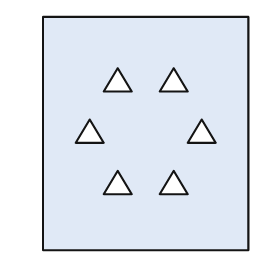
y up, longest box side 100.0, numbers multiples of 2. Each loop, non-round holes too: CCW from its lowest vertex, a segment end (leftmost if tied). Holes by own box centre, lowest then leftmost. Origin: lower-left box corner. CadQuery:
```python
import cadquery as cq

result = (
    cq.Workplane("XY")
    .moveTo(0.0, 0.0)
    .lineTo(88.0, 0.0)
    .lineTo(88.0, 100.0)
    .lineTo(0.0, 100.0)
    .close()
    .moveTo(26.0, 24.0)
    .lineTo(38.0, 24.0)
    .lineTo(32.0, 34.0)
    .close()
    .moveTo(50.0, 24.0)
    .lineTo(62.0, 24.0)
    .lineTo(56.0, 34.0)
    .close()
    .moveTo(14.0, 46.0)
    .lineTo(26.0, 46.0)
    .lineTo(20.0, 56.0)
    .close()
    .moveTo(62.0, 46.0)
    .lineTo(74.0, 46.0)
    .lineTo(68.0, 56.0)
    .close()
    .moveTo(26.0, 68.0)
    .lineTo(38.0, 68.0)
    .lineTo(32.0, 78.0)
    .close()
    .moveTo(50.0, 68.0)
    .lineTo(62.0, 68.0)
    .lineTo(56.0, 78.0)
    .close()
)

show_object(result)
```